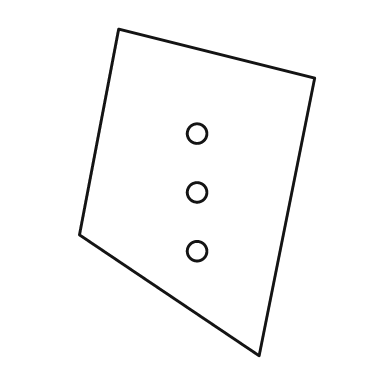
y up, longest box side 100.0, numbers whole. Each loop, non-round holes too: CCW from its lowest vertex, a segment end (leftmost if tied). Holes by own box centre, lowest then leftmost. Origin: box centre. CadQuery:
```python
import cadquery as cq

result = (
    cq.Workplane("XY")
    .moveTo(19.0, -50.0)
    .lineTo(36.0, 35.0)
    .lineTo(-24.0, 50.0)
    .lineTo(-36.0, -13.0)
    .close()
    .moveTo(0.0, -18.0)
    .circle(3.0)
    .moveTo(0.0, 0.0)
    .circle(3.0)
    .moveTo(0.0, 18.0)
    .circle(3.0)
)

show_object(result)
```